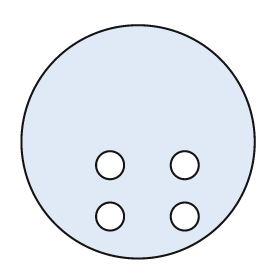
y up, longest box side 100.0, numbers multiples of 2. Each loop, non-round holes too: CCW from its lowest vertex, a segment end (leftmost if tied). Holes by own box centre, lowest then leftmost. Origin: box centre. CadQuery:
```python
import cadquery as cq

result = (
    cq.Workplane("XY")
    .moveTo(0.0, 0.0)
    .circle(50.0)
    .moveTo(-12.0, -32.0)
    .circle(6.0)
    .moveTo(20.0, -32.0)
    .circle(6.0)
    .moveTo(-12.0, -10.0)
    .circle(6.0)
    .moveTo(20.0, -10.0)
    .circle(6.0)
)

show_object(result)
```